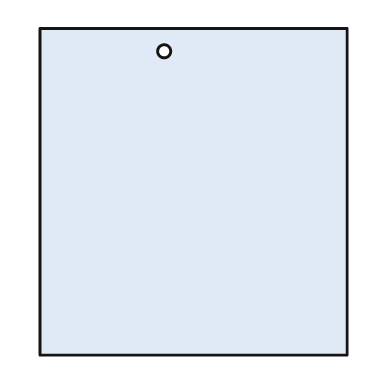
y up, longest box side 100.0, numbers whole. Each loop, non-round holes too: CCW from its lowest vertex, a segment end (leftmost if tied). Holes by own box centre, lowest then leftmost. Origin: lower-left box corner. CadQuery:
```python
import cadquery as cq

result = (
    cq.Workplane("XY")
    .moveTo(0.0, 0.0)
    .lineTo(94.0, 0.0)
    .lineTo(94.0, 100.0)
    .lineTo(0.0, 100.0)
    .close()
    .moveTo(38.0, 93.0)
    .circle(2.0)
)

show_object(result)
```